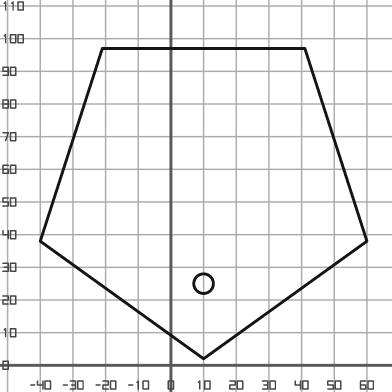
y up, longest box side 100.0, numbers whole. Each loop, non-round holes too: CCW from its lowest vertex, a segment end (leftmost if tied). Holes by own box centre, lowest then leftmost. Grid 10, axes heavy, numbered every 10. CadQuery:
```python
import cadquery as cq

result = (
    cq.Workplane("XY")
    .moveTo(10.0, 2.0)
    .lineTo(60.0, 38.0)
    .lineTo(41.0, 97.0)
    .lineTo(-21.0, 97.0)
    .lineTo(-40.0, 38.0)
    .close()
    .moveTo(10.0, 25.0)
    .circle(3.0)
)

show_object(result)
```